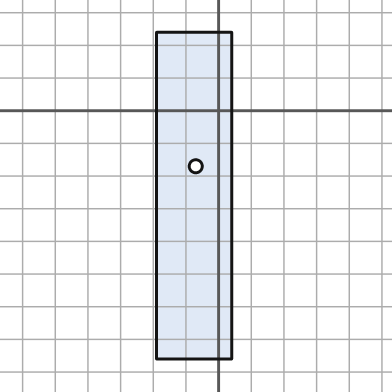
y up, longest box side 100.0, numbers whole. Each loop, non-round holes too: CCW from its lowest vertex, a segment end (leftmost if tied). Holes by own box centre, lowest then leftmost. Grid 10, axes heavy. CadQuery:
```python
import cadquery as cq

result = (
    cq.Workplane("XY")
    .moveTo(-19.0, -76.0)
    .lineTo(4.0, -76.0)
    .lineTo(4.0, 24.0)
    .lineTo(-19.0, 24.0)
    .close()
    .moveTo(-7.0, -17.0)
    .circle(2.0)
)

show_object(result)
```